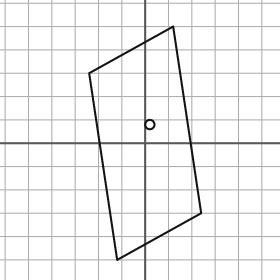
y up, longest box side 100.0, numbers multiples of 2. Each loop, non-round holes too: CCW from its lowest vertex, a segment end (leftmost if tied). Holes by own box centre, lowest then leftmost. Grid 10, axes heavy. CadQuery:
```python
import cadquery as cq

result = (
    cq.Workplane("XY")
    .moveTo(-12.0, -50.0)
    .lineTo(24.0, -30.0)
    .lineTo(12.0, 50.0)
    .lineTo(-24.0, 30.0)
    .close()
    .moveTo(2.0, 8.0)
    .circle(2.0)
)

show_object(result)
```